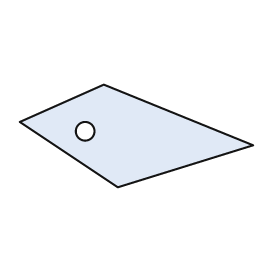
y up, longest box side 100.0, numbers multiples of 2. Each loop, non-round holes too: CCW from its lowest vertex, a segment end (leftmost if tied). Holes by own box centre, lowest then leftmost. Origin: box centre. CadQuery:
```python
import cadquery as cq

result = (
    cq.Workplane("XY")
    .moveTo(-8.0, -22.0)
    .lineTo(50.0, -4.0)
    .lineTo(-14.0, 22.0)
    .lineTo(-50.0, 6.0)
    .close()
    .moveTo(-22.0, 2.0)
    .circle(4.0)
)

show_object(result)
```